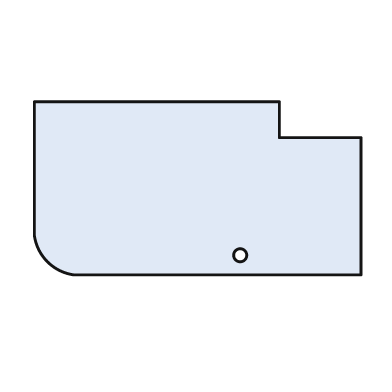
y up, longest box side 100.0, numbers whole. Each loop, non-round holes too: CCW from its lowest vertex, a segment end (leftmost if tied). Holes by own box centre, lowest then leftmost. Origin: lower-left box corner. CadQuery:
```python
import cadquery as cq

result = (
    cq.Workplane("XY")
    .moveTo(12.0, 0.0)
    .lineTo(100.0, 0.0)
    .lineTo(100.0, 42.0)
    .lineTo(75.0, 42.0)
    .lineTo(75.0, 53.0)
    .lineTo(0.0, 53.0)
    .lineTo(0.0, 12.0)
    .threePointArc((4.0, 4.0), (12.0, 0.0))
    .close()
    .moveTo(63.0, 6.0)
    .circle(2.0)
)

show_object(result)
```